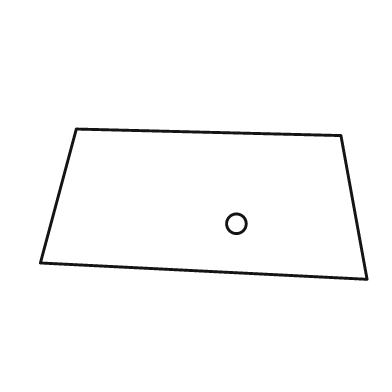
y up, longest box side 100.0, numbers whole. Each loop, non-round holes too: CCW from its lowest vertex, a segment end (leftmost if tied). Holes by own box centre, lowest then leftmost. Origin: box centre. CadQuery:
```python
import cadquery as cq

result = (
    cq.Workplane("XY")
    .moveTo(50.0, -23.0)
    .lineTo(42.0, 21.0)
    .lineTo(-39.0, 23.0)
    .lineTo(-50.0, -18.0)
    .close()
    .moveTo(10.0, -6.0)
    .circle(3.0)
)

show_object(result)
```